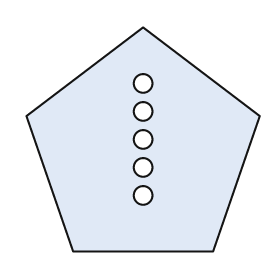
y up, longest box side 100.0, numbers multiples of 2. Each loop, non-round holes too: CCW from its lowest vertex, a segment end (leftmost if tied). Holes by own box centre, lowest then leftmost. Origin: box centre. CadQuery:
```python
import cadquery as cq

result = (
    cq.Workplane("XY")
    .moveTo(-30.0, -48.0)
    .lineTo(30.0, -48.0)
    .lineTo(50.0, 10.0)
    .lineTo(0.0, 48.0)
    .lineTo(-50.0, 10.0)
    .close()
    .moveTo(0.0, -24.0)
    .circle(4.0)
    .moveTo(0.0, -12.0)
    .circle(4.0)
    .moveTo(0.0, 0.0)
    .circle(4.0)
    .moveTo(0.0, 12.0)
    .circle(4.0)
    .moveTo(0.0, 24.0)
    .circle(4.0)
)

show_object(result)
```